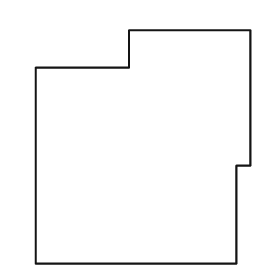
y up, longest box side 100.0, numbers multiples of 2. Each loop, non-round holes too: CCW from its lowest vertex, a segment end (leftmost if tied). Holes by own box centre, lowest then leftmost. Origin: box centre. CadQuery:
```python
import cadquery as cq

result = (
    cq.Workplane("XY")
    .moveTo(-46.0, -50.0)
    .lineTo(40.0, -50.0)
    .lineTo(40.0, -8.0)
    .lineTo(46.0, -8.0)
    .lineTo(46.0, 50.0)
    .lineTo(-6.0, 50.0)
    .lineTo(-6.0, 34.0)
    .lineTo(-46.0, 34.0)
    .close()
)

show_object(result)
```